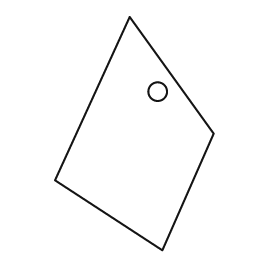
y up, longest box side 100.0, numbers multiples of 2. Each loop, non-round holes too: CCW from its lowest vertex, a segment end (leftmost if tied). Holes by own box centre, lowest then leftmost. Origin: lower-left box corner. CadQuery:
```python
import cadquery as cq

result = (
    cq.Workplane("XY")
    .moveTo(46.0, 0.0)
    .lineTo(68.0, 50.0)
    .lineTo(32.0, 100.0)
    .lineTo(0.0, 30.0)
    .close()
    .moveTo(44.0, 68.0)
    .circle(4.0)
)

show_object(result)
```